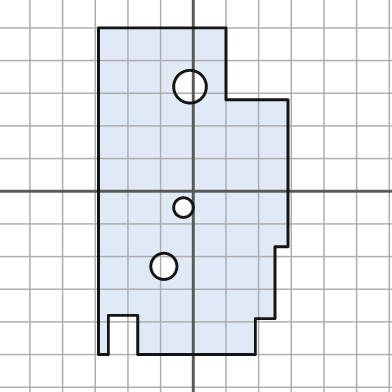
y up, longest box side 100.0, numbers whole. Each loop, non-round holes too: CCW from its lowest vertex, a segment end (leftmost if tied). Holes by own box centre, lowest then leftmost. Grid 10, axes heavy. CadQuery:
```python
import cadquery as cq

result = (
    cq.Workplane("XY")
    .moveTo(-29.0, -50.0)
    .lineTo(-26.0, -50.0)
    .lineTo(-26.0, -38.0)
    .lineTo(-17.0, -38.0)
    .lineTo(-17.0, -50.0)
    .lineTo(19.0, -50.0)
    .lineTo(19.0, -39.0)
    .lineTo(25.0, -39.0)
    .lineTo(25.0, -17.0)
    .lineTo(29.0, -17.0)
    .lineTo(29.0, 28.0)
    .lineTo(10.0, 28.0)
    .lineTo(10.0, 50.0)
    .lineTo(-29.0, 50.0)
    .close()
    .moveTo(-9.0, -23.0)
    .circle(4.0)
    .moveTo(-3.0, -5.0)
    .circle(3.0)
    .moveTo(-1.0, 32.0)
    .circle(5.0)
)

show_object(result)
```